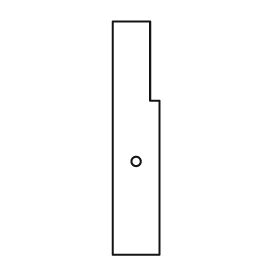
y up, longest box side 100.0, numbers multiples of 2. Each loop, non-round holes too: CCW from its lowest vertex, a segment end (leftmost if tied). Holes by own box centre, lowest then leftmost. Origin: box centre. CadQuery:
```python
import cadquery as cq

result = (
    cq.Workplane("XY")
    .moveTo(-10.0, -50.0)
    .lineTo(10.0, -50.0)
    .lineTo(10.0, 16.0)
    .lineTo(6.0, 16.0)
    .lineTo(6.0, 50.0)
    .lineTo(-10.0, 50.0)
    .close()
    .moveTo(0.0, -10.0)
    .circle(2.0)
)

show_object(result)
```